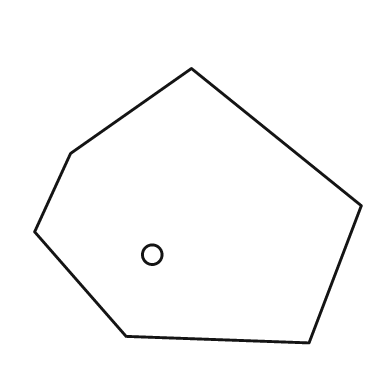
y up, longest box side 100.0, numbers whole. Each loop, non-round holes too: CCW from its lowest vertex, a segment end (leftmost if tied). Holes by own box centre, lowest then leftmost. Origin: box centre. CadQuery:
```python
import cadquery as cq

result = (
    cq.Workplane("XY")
    .moveTo(34.0, -42.0)
    .lineTo(50.0, 0.0)
    .lineTo(-2.0, 42.0)
    .lineTo(-39.0, 16.0)
    .lineTo(-50.0, -8.0)
    .lineTo(-22.0, -40.0)
    .close()
    .moveTo(-14.0, -15.0)
    .circle(3.0)
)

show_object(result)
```